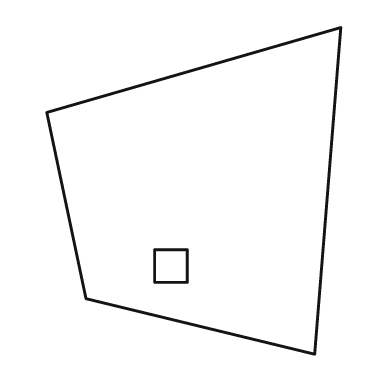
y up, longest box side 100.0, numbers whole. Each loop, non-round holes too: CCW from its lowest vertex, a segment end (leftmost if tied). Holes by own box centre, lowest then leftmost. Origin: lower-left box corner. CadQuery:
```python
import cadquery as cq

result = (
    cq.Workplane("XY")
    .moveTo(82.0, 0.0)
    .lineTo(90.0, 100.0)
    .lineTo(0.0, 74.0)
    .lineTo(12.0, 17.0)
    .close()
    .moveTo(33.0, 22.0)
    .lineTo(43.0, 22.0)
    .lineTo(43.0, 32.0)
    .lineTo(33.0, 32.0)
    .close()
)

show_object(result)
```